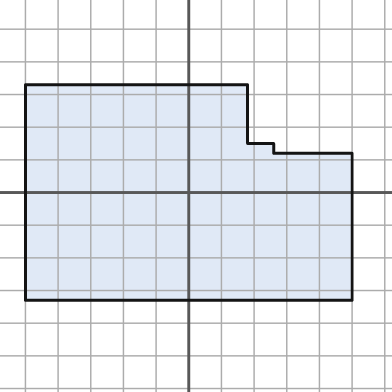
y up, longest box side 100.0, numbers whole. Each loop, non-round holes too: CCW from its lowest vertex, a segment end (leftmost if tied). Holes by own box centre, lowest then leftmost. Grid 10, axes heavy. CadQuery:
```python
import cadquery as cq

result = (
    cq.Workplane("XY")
    .moveTo(-50.0, -33.0)
    .lineTo(50.0, -33.0)
    .lineTo(50.0, 12.0)
    .lineTo(26.0, 12.0)
    .lineTo(26.0, 15.0)
    .lineTo(18.0, 15.0)
    .lineTo(18.0, 33.0)
    .lineTo(-50.0, 33.0)
    .close()
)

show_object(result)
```